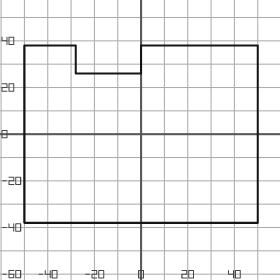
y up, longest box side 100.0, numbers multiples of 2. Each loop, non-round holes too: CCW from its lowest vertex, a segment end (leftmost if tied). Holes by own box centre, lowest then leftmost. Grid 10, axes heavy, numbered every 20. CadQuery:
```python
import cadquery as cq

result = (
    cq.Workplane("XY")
    .moveTo(-50.0, -38.0)
    .lineTo(50.0, -38.0)
    .lineTo(50.0, 38.0)
    .lineTo(0.0, 38.0)
    .lineTo(0.0, 26.0)
    .lineTo(-28.0, 26.0)
    .lineTo(-28.0, 38.0)
    .lineTo(-50.0, 38.0)
    .close()
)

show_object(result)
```